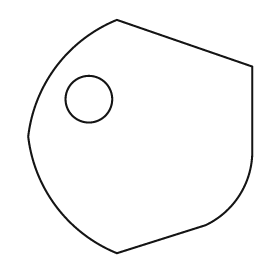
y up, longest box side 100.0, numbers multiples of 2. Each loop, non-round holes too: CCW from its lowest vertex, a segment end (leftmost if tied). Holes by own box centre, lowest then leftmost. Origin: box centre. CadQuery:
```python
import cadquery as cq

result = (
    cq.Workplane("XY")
    .moveTo(-10.0, -50.0)
    .lineTo(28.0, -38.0)
    .threePointArc((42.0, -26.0), (48.0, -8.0))
    .lineTo(48.0, 30.0)
    .lineTo(-10.0, 50.0)
    .threePointArc((-36.0, 30.0), (-48.0, 0.0))
    .threePointArc((-36.0, -30.0), (-10.0, -50.0))
    .close()
    .moveTo(-22.0, 16.0)
    .circle(10.0)
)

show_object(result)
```